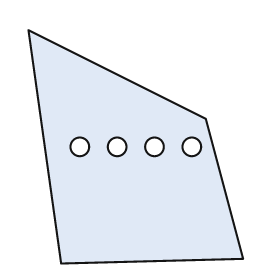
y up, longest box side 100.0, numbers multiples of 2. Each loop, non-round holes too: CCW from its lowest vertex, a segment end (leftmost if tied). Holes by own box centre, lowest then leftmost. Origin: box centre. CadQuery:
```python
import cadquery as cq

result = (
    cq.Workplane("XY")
    .moveTo(-32.0, -50.0)
    .lineTo(46.0, -48.0)
    .lineTo(30.0, 12.0)
    .lineTo(-46.0, 50.0)
    .close()
    .moveTo(-24.0, 0.0)
    .circle(4.0)
    .moveTo(-8.0, 0.0)
    .circle(4.0)
    .moveTo(8.0, 0.0)
    .circle(4.0)
    .moveTo(24.0, 0.0)
    .circle(4.0)
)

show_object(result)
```